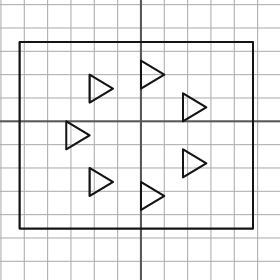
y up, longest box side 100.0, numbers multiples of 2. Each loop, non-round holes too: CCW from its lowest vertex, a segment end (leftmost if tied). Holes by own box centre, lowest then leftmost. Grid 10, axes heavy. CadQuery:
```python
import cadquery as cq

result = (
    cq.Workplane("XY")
    .moveTo(-52.0, -46.0)
    .lineTo(48.0, -46.0)
    .lineTo(48.0, 34.0)
    .lineTo(-52.0, 34.0)
    .close()
    .moveTo(0.0, -38.0)
    .lineTo(10.0, -32.0)
    .lineTo(0.0, -26.0)
    .close()
    .moveTo(-22.0, -32.0)
    .lineTo(-12.0, -26.0)
    .lineTo(-22.0, -20.0)
    .close()
    .moveTo(18.0, -24.0)
    .lineTo(28.0, -18.0)
    .lineTo(18.0, -12.0)
    .close()
    .moveTo(-32.0, -12.0)
    .lineTo(-22.0, -6.0)
    .lineTo(-32.0, 0.0)
    .close()
    .moveTo(18.0, 0.0)
    .lineTo(28.0, 6.0)
    .lineTo(18.0, 12.0)
    .close()
    .moveTo(-22.0, 8.0)
    .lineTo(-12.0, 14.0)
    .lineTo(-22.0, 20.0)
    .close()
    .moveTo(0.0, 14.0)
    .lineTo(10.0, 20.0)
    .lineTo(0.0, 26.0)
    .close()
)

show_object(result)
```